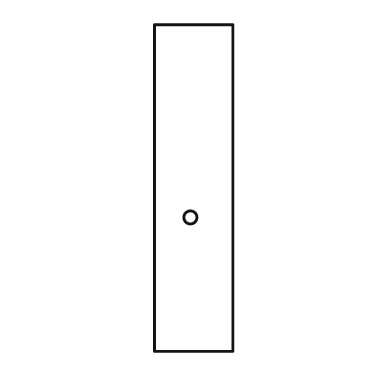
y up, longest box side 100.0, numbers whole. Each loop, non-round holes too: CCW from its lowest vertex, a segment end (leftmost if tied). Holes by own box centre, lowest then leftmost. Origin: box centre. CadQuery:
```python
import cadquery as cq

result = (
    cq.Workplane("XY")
    .moveTo(-12.0, -50.0)
    .lineTo(12.0, -50.0)
    .lineTo(12.0, 50.0)
    .lineTo(-12.0, 50.0)
    .close()
    .moveTo(-1.0, -9.0)
    .circle(2.0)
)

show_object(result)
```